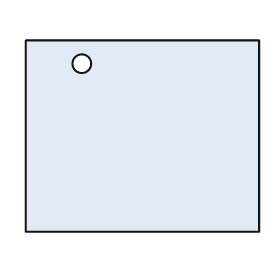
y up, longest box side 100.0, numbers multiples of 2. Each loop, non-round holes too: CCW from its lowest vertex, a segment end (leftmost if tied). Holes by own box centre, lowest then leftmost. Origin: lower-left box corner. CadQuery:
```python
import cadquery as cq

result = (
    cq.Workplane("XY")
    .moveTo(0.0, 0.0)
    .lineTo(100.0, 0.0)
    .lineTo(100.0, 82.0)
    .lineTo(0.0, 82.0)
    .close()
    .moveTo(24.0, 72.0)
    .circle(4.0)
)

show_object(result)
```